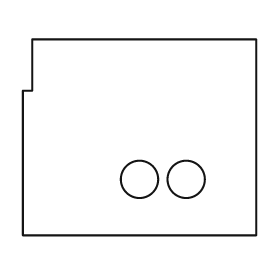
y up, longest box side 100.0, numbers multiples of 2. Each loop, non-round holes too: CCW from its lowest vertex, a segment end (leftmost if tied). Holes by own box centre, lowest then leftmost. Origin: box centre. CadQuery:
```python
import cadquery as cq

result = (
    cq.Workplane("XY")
    .moveTo(-50.0, -42.0)
    .lineTo(50.0, -42.0)
    .lineTo(50.0, 42.0)
    .lineTo(-46.0, 42.0)
    .lineTo(-46.0, 20.0)
    .lineTo(-50.0, 20.0)
    .close()
    .moveTo(0.0, -18.0)
    .circle(8.0)
    .moveTo(20.0, -18.0)
    .circle(8.0)
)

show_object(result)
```